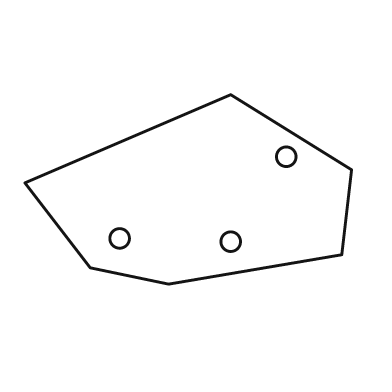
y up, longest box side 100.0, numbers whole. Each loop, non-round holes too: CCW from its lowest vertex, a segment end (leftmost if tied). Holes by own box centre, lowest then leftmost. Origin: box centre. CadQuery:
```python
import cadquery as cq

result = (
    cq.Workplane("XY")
    .moveTo(-6.0, -29.0)
    .lineTo(47.0, -20.0)
    .lineTo(50.0, 6.0)
    .lineTo(13.0, 29.0)
    .lineTo(-50.0, 2.0)
    .lineTo(-30.0, -24.0)
    .close()
    .moveTo(13.0, -16.0)
    .circle(3.0)
    .moveTo(-21.0, -15.0)
    .circle(3.0)
    .moveTo(30.0, 10.0)
    .circle(3.0)
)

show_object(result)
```